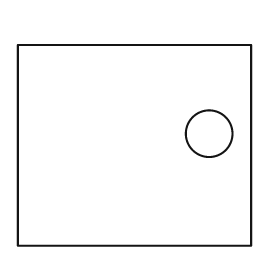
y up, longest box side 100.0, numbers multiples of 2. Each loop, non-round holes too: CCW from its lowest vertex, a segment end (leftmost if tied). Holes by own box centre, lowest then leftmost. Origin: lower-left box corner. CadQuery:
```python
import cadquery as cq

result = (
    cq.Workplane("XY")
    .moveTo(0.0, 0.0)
    .lineTo(100.0, 0.0)
    .lineTo(100.0, 86.0)
    .lineTo(0.0, 86.0)
    .close()
    .moveTo(82.0, 48.0)
    .circle(10.0)
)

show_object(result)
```